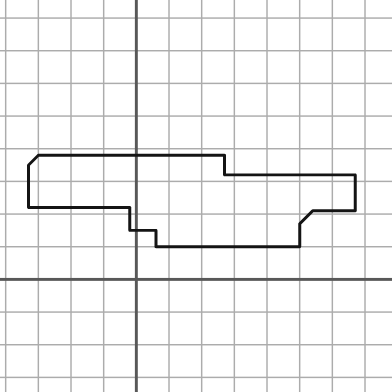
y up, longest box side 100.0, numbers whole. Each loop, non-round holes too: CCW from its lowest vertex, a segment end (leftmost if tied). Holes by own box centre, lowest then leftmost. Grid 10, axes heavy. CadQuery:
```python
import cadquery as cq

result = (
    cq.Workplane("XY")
    .moveTo(6.0, 10.0)
    .lineTo(50.0, 10.0)
    .lineTo(50.0, 17.0)
    .lineTo(54.0, 21.0)
    .lineTo(67.0, 21.0)
    .lineTo(67.0, 32.0)
    .lineTo(27.0, 32.0)
    .lineTo(27.0, 38.0)
    .lineTo(-30.0, 38.0)
    .lineTo(-33.0, 35.0)
    .lineTo(-33.0, 22.0)
    .lineTo(-2.0, 22.0)
    .lineTo(-2.0, 15.0)
    .lineTo(6.0, 15.0)
    .close()
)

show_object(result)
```